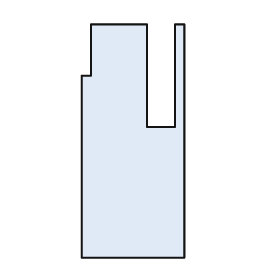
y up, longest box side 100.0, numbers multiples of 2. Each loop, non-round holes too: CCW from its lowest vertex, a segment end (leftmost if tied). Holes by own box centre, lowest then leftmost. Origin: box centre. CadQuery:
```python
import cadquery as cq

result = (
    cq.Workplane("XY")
    .moveTo(-22.0, -50.0)
    .lineTo(22.0, -50.0)
    .lineTo(22.0, 50.0)
    .lineTo(18.0, 50.0)
    .lineTo(18.0, 6.0)
    .lineTo(6.0, 6.0)
    .lineTo(6.0, 50.0)
    .lineTo(-18.0, 50.0)
    .lineTo(-18.0, 28.0)
    .lineTo(-22.0, 28.0)
    .close()
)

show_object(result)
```